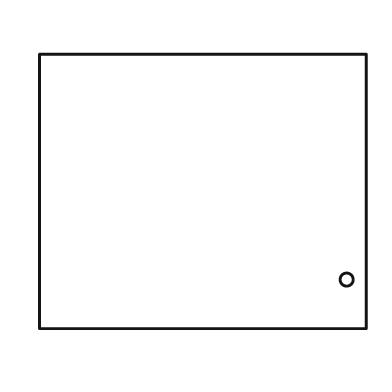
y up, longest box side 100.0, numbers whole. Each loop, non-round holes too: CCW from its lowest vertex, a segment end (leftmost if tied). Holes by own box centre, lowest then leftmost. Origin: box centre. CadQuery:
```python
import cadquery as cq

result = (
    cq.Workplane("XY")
    .moveTo(-50.0, -42.0)
    .lineTo(50.0, -42.0)
    .lineTo(50.0, 42.0)
    .lineTo(-50.0, 42.0)
    .close()
    .moveTo(44.0, -27.0)
    .circle(2.0)
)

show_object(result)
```